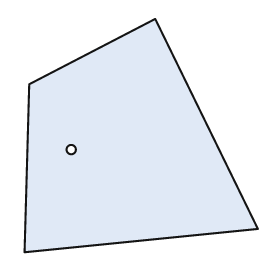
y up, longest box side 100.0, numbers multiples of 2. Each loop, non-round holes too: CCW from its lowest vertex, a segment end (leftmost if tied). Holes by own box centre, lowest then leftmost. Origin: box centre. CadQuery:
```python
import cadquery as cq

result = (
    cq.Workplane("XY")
    .moveTo(-50.0, -50.0)
    .lineTo(50.0, -40.0)
    .lineTo(6.0, 50.0)
    .lineTo(-48.0, 22.0)
    .close()
    .moveTo(-30.0, -6.0)
    .circle(2.0)
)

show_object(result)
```